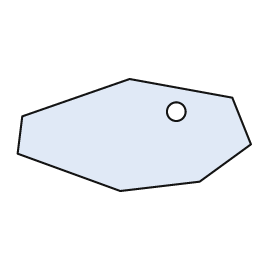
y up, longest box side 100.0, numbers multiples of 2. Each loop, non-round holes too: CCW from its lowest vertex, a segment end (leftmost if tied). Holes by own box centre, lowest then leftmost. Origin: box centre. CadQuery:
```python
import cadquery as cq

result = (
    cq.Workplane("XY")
    .moveTo(-6.0, -24.0)
    .lineTo(28.0, -20.0)
    .lineTo(50.0, -4.0)
    .lineTo(42.0, 16.0)
    .lineTo(-2.0, 24.0)
    .lineTo(-48.0, 8.0)
    .lineTo(-50.0, -8.0)
    .close()
    .moveTo(18.0, 10.0)
    .circle(4.0)
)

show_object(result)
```